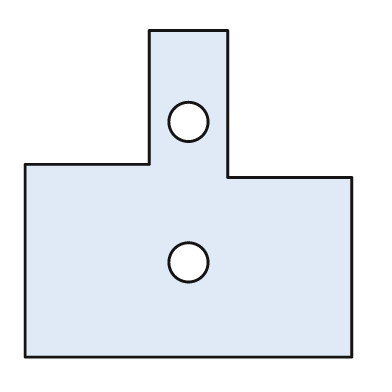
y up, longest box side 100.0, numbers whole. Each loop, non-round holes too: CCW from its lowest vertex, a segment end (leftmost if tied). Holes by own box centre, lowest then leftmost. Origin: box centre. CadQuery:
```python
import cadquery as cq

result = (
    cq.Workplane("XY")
    .moveTo(-50.0, -50.0)
    .lineTo(50.0, -50.0)
    .lineTo(50.0, 5.0)
    .lineTo(12.0, 5.0)
    .lineTo(12.0, 50.0)
    .lineTo(-12.0, 50.0)
    .lineTo(-12.0, 9.0)
    .lineTo(-50.0, 9.0)
    .close()
    .moveTo(0.0, -21.0)
    .circle(6.0)
    .moveTo(0.0, 22.0)
    .circle(6.0)
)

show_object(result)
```